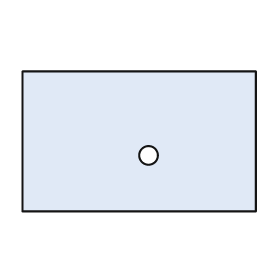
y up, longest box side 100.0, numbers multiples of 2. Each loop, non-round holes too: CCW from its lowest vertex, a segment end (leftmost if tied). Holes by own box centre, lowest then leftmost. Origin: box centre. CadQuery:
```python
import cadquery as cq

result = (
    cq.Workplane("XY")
    .moveTo(-50.0, -30.0)
    .lineTo(50.0, -30.0)
    .lineTo(50.0, 30.0)
    .lineTo(-50.0, 30.0)
    .close()
    .moveTo(4.0, -6.0)
    .circle(4.0)
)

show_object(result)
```